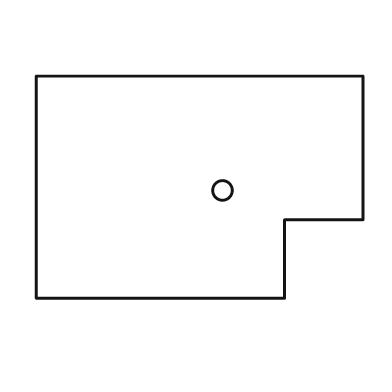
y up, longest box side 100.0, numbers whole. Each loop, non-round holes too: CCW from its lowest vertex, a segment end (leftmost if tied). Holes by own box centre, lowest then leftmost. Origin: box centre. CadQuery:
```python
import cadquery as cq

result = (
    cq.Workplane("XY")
    .moveTo(-50.0, -34.0)
    .lineTo(26.0, -34.0)
    .lineTo(26.0, -10.0)
    .lineTo(50.0, -10.0)
    .lineTo(50.0, 34.0)
    .lineTo(-50.0, 34.0)
    .close()
    .moveTo(7.0, -1.0)
    .circle(3.0)
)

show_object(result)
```